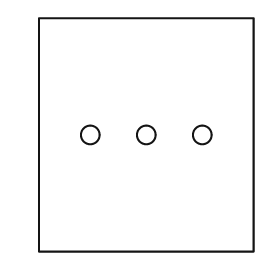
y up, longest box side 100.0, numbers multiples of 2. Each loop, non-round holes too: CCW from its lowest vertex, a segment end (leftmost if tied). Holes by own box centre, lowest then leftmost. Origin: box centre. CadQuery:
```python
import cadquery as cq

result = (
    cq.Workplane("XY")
    .moveTo(-46.0, -50.0)
    .lineTo(46.0, -50.0)
    .lineTo(46.0, 50.0)
    .lineTo(-46.0, 50.0)
    .close()
    .moveTo(-24.0, 0.0)
    .circle(4.0)
    .moveTo(0.0, 0.0)
    .circle(4.0)
    .moveTo(24.0, 0.0)
    .circle(4.0)
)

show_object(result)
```